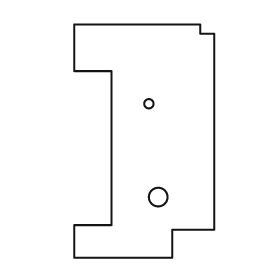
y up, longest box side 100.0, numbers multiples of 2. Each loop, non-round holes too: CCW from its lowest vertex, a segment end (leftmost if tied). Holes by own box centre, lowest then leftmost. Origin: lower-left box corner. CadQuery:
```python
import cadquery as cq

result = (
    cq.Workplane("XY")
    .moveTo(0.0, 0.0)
    .lineTo(42.0, 0.0)
    .lineTo(42.0, 12.0)
    .lineTo(60.0, 12.0)
    .lineTo(60.0, 96.0)
    .lineTo(54.0, 96.0)
    .lineTo(54.0, 100.0)
    .lineTo(0.0, 100.0)
    .lineTo(0.0, 80.0)
    .lineTo(16.0, 80.0)
    .lineTo(16.0, 14.0)
    .lineTo(0.0, 14.0)
    .close()
    .moveTo(36.0, 26.0)
    .circle(4.0)
    .moveTo(32.0, 66.0)
    .circle(2.0)
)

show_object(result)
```